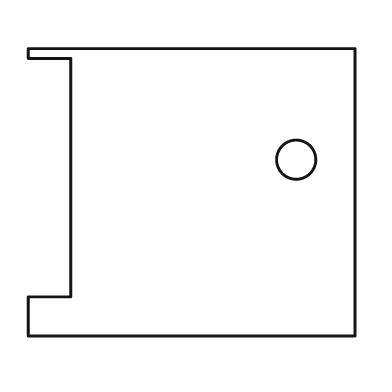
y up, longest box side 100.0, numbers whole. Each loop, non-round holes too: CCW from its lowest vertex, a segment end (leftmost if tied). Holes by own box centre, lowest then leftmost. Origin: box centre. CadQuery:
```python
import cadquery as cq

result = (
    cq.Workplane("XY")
    .moveTo(-50.0, -44.0)
    .lineTo(50.0, -44.0)
    .lineTo(50.0, 44.0)
    .lineTo(-50.0, 44.0)
    .lineTo(-50.0, 41.0)
    .lineTo(-37.0, 41.0)
    .lineTo(-37.0, -32.0)
    .lineTo(-50.0, -32.0)
    .close()
    .moveTo(32.0, 10.0)
    .circle(6.0)
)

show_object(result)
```